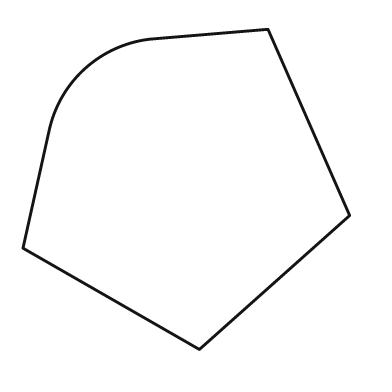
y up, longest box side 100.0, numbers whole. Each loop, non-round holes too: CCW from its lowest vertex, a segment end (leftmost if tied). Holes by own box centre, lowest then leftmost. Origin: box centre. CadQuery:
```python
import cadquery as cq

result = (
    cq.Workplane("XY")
    .moveTo(4.0, -49.0)
    .lineTo(50.0, -8.0)
    .lineTo(25.0, 49.0)
    .lineTo(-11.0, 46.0)
    .threePointArc((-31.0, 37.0), (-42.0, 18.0))
    .lineTo(-50.0, -18.0)
    .close()
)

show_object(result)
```